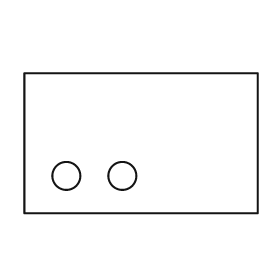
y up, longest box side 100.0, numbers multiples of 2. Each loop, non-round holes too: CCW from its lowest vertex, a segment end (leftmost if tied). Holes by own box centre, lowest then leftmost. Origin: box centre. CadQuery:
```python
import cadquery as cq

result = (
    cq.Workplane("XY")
    .moveTo(-50.0, -30.0)
    .lineTo(50.0, -30.0)
    .lineTo(50.0, 30.0)
    .lineTo(-50.0, 30.0)
    .close()
    .moveTo(-32.0, -14.0)
    .circle(6.0)
    .moveTo(-8.0, -14.0)
    .circle(6.0)
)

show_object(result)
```